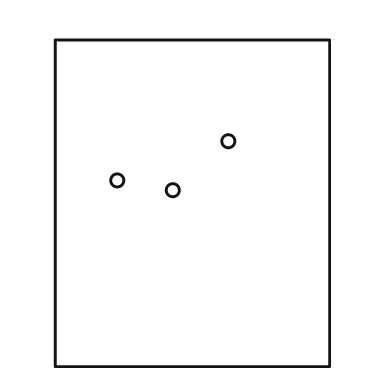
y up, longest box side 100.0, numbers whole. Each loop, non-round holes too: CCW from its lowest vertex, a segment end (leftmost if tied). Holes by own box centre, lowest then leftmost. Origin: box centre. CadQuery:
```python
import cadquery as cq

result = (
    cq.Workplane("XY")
    .moveTo(-42.0, -50.0)
    .lineTo(42.0, -50.0)
    .lineTo(42.0, 50.0)
    .lineTo(-42.0, 50.0)
    .close()
    .moveTo(-6.0, 4.0)
    .circle(2.0)
    .moveTo(-23.0, 7.0)
    .circle(2.0)
    .moveTo(11.0, 19.0)
    .circle(2.0)
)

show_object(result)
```